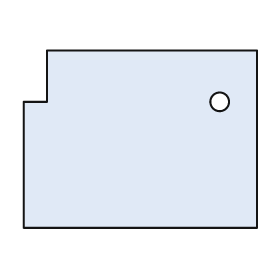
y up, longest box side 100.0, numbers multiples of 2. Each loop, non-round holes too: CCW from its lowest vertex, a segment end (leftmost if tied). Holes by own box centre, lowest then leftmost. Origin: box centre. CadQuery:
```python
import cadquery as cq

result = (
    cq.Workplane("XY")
    .moveTo(-50.0, -38.0)
    .lineTo(50.0, -38.0)
    .lineTo(50.0, 38.0)
    .lineTo(-40.0, 38.0)
    .lineTo(-40.0, 16.0)
    .lineTo(-50.0, 16.0)
    .close()
    .moveTo(34.0, 16.0)
    .circle(4.0)
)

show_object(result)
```